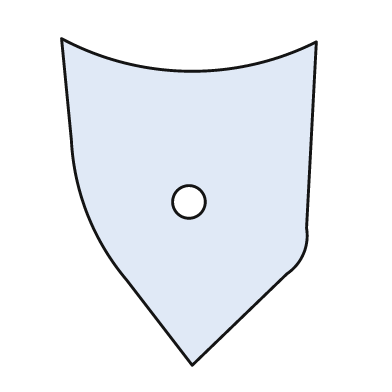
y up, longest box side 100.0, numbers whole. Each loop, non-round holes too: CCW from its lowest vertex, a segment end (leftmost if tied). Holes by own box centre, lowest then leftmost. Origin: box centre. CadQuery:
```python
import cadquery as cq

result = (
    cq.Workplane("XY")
    .moveTo(1.0, -50.0)
    .lineTo(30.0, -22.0)
    .threePointArc((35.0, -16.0), (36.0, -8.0))
    .lineTo(39.0, 49.0)
    .threePointArc((0.0, 40.0), (-39.0, 50.0))
    .lineTo(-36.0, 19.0)
    .threePointArc((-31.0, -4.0), (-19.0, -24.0))
    .close()
    .moveTo(0.0, 0.0)
    .circle(5.0)
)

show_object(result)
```